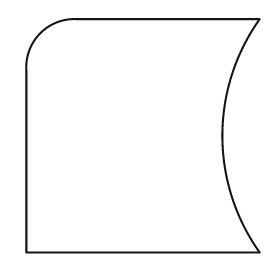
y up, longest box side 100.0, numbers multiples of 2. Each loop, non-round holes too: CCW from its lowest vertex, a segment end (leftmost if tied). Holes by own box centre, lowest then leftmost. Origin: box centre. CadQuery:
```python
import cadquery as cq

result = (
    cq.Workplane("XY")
    .moveTo(-50.0, -50.0)
    .lineTo(50.0, -50.0)
    .threePointArc((34.0, 0.0), (50.0, 50.0))
    .lineTo(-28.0, 50.0)
    .threePointArc((-44.0, 44.0), (-50.0, 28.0))
    .close()
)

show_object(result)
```